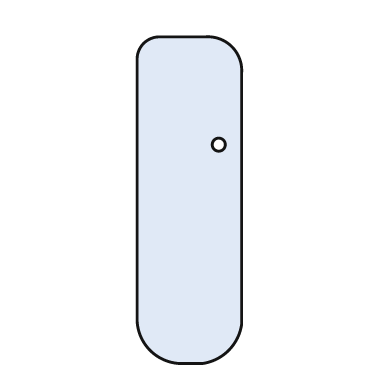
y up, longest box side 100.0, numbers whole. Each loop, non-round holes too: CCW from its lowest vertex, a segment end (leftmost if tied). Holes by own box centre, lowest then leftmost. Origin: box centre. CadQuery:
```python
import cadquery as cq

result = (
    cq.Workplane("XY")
    .moveTo(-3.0, -50.0)
    .lineTo(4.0, -50.0)
    .threePointArc((12.0, -46.0), (16.0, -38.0))
    .lineTo(16.0, 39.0)
    .threePointArc((13.0, 47.0), (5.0, 50.0))
    .lineTo(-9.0, 50.0)
    .threePointArc((-14.0, 48.0), (-16.0, 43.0))
    .lineTo(-16.0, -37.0)
    .threePointArc((-12.0, -46.0), (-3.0, -50.0))
    .close()
    .moveTo(9.0, 17.0)
    .circle(2.0)
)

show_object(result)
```